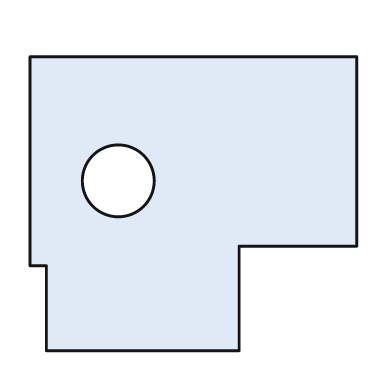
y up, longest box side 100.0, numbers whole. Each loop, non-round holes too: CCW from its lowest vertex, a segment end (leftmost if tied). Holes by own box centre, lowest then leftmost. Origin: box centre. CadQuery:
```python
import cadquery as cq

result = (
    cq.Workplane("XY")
    .moveTo(-45.0, -45.0)
    .lineTo(14.0, -45.0)
    .lineTo(14.0, -13.0)
    .lineTo(50.0, -13.0)
    .lineTo(50.0, 45.0)
    .lineTo(-50.0, 45.0)
    .lineTo(-50.0, -19.0)
    .lineTo(-45.0, -19.0)
    .close()
    .moveTo(-23.0, 7.0)
    .circle(11.0)
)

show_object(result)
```